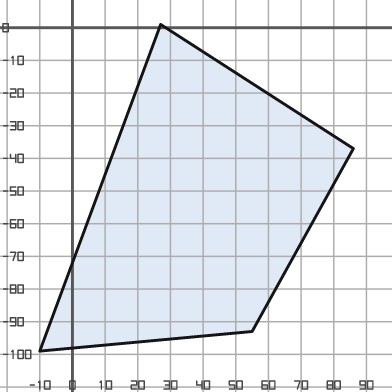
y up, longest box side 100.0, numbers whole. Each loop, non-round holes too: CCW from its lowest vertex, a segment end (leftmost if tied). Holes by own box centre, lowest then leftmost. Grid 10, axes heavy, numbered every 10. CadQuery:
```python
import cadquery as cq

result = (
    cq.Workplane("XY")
    .moveTo(-10.0, -99.0)
    .lineTo(55.0, -93.0)
    .lineTo(86.0, -37.0)
    .lineTo(27.0, 1.0)
    .close()
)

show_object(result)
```